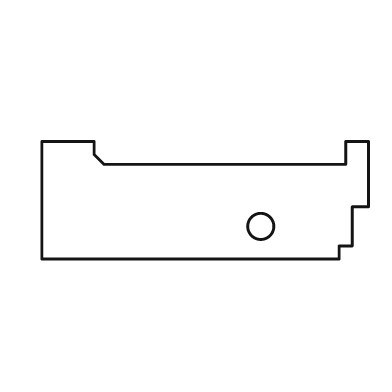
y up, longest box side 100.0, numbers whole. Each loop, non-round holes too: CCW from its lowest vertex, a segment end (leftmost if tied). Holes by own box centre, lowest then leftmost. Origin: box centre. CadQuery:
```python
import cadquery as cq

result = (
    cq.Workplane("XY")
    .moveTo(-50.0, -18.0)
    .lineTo(41.0, -18.0)
    .lineTo(41.0, -14.0)
    .lineTo(45.0, -14.0)
    .lineTo(45.0, -2.0)
    .lineTo(50.0, -2.0)
    .lineTo(50.0, 18.0)
    .lineTo(43.0, 18.0)
    .lineTo(43.0, 11.0)
    .lineTo(-31.0, 11.0)
    .lineTo(-34.0, 14.0)
    .lineTo(-34.0, 18.0)
    .lineTo(-50.0, 18.0)
    .close()
    .moveTo(17.0, -8.0)
    .circle(4.0)
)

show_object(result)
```